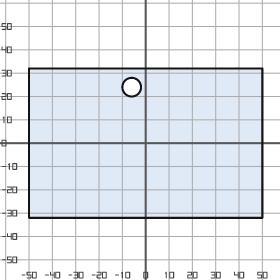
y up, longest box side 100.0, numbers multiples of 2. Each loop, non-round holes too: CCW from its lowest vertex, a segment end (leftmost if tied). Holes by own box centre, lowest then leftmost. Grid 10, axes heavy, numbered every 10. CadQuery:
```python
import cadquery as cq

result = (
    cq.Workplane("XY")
    .moveTo(-50.0, -32.0)
    .lineTo(50.0, -32.0)
    .lineTo(50.0, 32.0)
    .lineTo(-50.0, 32.0)
    .close()
    .moveTo(-6.0, 24.0)
    .circle(4.0)
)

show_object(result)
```